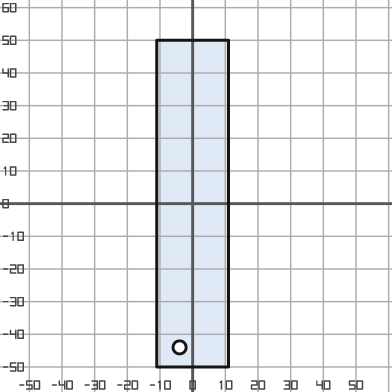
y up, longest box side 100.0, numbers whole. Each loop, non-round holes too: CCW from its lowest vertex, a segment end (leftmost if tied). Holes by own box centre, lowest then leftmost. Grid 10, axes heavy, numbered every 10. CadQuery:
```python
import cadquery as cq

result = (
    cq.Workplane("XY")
    .moveTo(-11.0, -50.0)
    .lineTo(11.0, -50.0)
    .lineTo(11.0, 50.0)
    .lineTo(-11.0, 50.0)
    .close()
    .moveTo(-4.0, -44.0)
    .circle(2.0)
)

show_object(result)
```